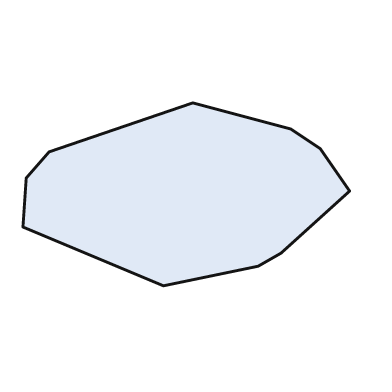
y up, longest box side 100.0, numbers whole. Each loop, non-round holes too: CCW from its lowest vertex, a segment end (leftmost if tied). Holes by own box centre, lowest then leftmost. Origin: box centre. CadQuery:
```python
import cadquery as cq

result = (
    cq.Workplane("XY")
    .moveTo(-7.0, -28.0)
    .lineTo(22.0, -22.0)
    .lineTo(29.0, -18.0)
    .lineTo(50.0, 1.0)
    .lineTo(41.0, 14.0)
    .lineTo(32.0, 20.0)
    .lineTo(2.0, 28.0)
    .lineTo(-42.0, 13.0)
    .lineTo(-49.0, 5.0)
    .lineTo(-50.0, -10.0)
    .close()
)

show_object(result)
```